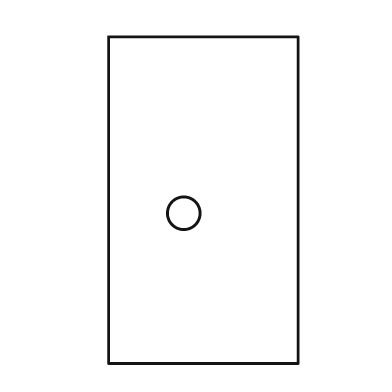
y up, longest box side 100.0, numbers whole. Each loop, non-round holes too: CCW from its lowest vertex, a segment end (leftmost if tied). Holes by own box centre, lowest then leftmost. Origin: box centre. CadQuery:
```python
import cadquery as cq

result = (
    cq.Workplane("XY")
    .moveTo(-29.0, -50.0)
    .lineTo(29.0, -50.0)
    .lineTo(29.0, 50.0)
    .lineTo(-29.0, 50.0)
    .close()
    .moveTo(-6.0, -4.0)
    .circle(5.0)
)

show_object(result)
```